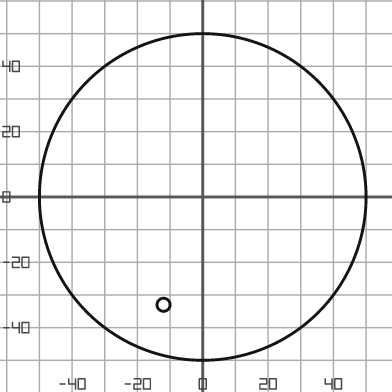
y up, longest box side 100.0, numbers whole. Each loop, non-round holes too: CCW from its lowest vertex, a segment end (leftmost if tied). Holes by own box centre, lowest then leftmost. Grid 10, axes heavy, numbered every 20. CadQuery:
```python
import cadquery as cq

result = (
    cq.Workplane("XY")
    .moveTo(0.0, 0.0)
    .circle(50.0)
    .moveTo(-12.0, -33.0)
    .circle(2.0)
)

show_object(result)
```